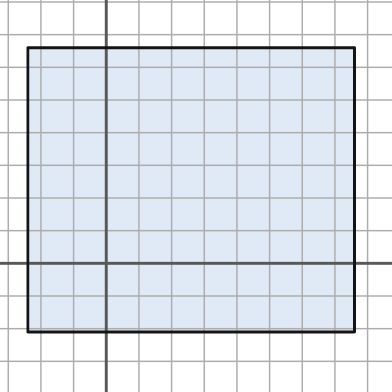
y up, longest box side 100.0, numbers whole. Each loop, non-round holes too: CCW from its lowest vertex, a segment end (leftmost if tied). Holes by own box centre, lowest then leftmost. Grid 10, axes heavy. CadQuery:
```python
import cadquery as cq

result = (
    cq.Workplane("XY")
    .moveTo(-24.0, -21.0)
    .lineTo(76.0, -21.0)
    .lineTo(76.0, 66.0)
    .lineTo(-24.0, 66.0)
    .close()
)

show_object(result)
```